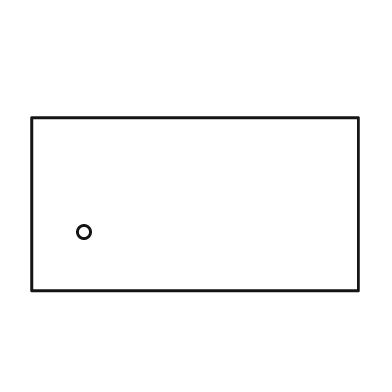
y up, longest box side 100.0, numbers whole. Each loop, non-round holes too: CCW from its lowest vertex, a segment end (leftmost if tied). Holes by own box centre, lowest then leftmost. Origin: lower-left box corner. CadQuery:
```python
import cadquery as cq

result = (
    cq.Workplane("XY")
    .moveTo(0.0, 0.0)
    .lineTo(100.0, 0.0)
    .lineTo(100.0, 53.0)
    .lineTo(0.0, 53.0)
    .close()
    .moveTo(16.0, 18.0)
    .circle(2.0)
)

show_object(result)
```